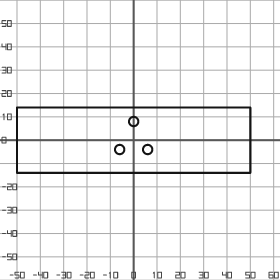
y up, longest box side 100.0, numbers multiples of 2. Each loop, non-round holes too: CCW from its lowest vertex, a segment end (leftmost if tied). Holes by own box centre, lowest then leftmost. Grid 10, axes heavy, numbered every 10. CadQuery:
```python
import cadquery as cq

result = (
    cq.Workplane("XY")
    .moveTo(-50.0, -14.0)
    .lineTo(50.0, -14.0)
    .lineTo(50.0, 14.0)
    .lineTo(-50.0, 14.0)
    .close()
    .moveTo(-6.0, -4.0)
    .circle(2.0)
    .moveTo(6.0, -4.0)
    .circle(2.0)
    .moveTo(0.0, 8.0)
    .circle(2.0)
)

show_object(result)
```